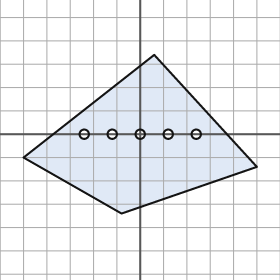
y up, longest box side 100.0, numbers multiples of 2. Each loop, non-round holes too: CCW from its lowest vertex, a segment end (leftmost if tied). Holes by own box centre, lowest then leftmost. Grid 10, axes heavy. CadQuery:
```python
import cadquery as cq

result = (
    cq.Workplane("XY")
    .moveTo(-8.0, -34.0)
    .lineTo(50.0, -14.0)
    .lineTo(6.0, 34.0)
    .lineTo(-50.0, -10.0)
    .close()
    .moveTo(-24.0, 0.0)
    .circle(2.0)
    .moveTo(-12.0, 0.0)
    .circle(2.0)
    .moveTo(0.0, 0.0)
    .circle(2.0)
    .moveTo(12.0, 0.0)
    .circle(2.0)
    .moveTo(24.0, 0.0)
    .circle(2.0)
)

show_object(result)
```